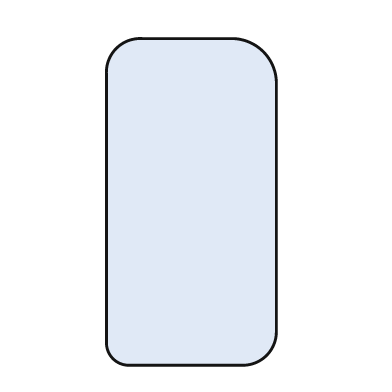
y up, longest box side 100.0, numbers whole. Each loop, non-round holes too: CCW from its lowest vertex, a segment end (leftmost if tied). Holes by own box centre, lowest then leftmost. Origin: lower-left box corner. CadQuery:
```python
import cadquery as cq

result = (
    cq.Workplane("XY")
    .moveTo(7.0, 0.0)
    .lineTo(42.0, 0.0)
    .threePointArc((49.0, 3.0), (52.0, 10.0))
    .lineTo(52.0, 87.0)
    .threePointArc((48.0, 96.0), (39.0, 100.0))
    .lineTo(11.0, 100.0)
    .threePointArc((3.0, 97.0), (0.0, 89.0))
    .lineTo(0.0, 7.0)
    .threePointArc((2.0, 2.0), (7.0, 0.0))
    .close()
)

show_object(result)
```